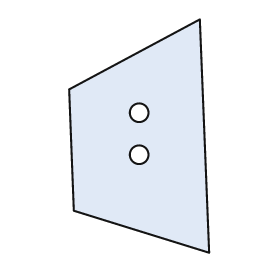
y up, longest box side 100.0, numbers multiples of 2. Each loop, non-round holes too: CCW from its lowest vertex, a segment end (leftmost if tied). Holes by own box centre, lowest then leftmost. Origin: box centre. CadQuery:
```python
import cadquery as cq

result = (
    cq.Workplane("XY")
    .moveTo(30.0, -50.0)
    .lineTo(26.0, 50.0)
    .lineTo(-30.0, 20.0)
    .lineTo(-28.0, -32.0)
    .close()
    .moveTo(0.0, -8.0)
    .circle(4.0)
    .moveTo(0.0, 10.0)
    .circle(4.0)
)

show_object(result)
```